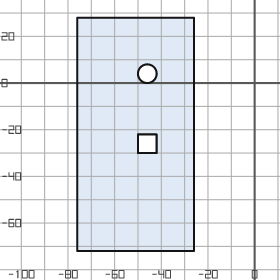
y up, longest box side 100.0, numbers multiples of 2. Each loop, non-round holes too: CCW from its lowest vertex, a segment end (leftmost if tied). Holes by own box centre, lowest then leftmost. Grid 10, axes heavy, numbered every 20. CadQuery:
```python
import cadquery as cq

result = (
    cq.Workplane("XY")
    .moveTo(-76.0, -72.0)
    .lineTo(-26.0, -72.0)
    .lineTo(-26.0, 28.0)
    .lineTo(-76.0, 28.0)
    .close()
    .moveTo(-50.0, -30.0)
    .lineTo(-42.0, -30.0)
    .lineTo(-42.0, -22.0)
    .lineTo(-50.0, -22.0)
    .close()
    .moveTo(-46.0, 4.0)
    .circle(4.0)
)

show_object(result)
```